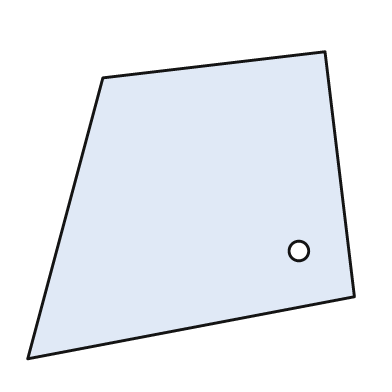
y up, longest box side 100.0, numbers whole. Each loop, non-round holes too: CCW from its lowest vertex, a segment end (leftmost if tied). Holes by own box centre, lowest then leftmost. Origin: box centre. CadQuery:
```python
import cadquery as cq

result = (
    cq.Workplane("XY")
    .moveTo(-50.0, -47.0)
    .lineTo(50.0, -28.0)
    .lineTo(41.0, 47.0)
    .lineTo(-27.0, 39.0)
    .close()
    .moveTo(33.0, -14.0)
    .circle(3.0)
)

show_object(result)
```